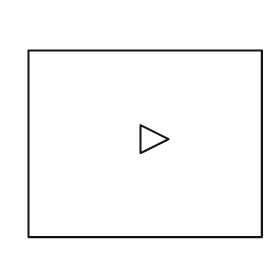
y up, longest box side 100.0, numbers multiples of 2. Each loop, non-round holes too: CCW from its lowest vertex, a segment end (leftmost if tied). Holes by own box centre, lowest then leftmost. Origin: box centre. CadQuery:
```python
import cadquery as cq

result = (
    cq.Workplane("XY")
    .moveTo(-50.0, -40.0)
    .lineTo(50.0, -40.0)
    .lineTo(50.0, 40.0)
    .lineTo(-50.0, 40.0)
    .close()
    .moveTo(-2.0, -4.0)
    .lineTo(10.0, 2.0)
    .lineTo(-2.0, 8.0)
    .close()
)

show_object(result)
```